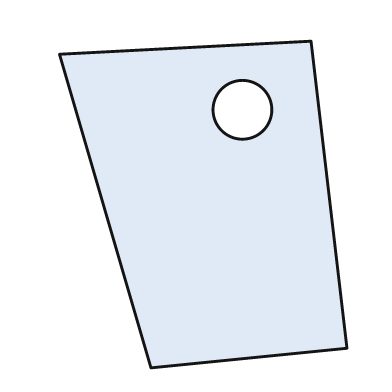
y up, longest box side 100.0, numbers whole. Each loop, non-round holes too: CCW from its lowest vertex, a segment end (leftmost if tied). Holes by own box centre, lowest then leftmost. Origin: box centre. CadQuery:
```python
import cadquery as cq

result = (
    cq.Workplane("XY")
    .moveTo(-16.0, -50.0)
    .lineTo(44.0, -44.0)
    .lineTo(33.0, 50.0)
    .lineTo(-44.0, 46.0)
    .close()
    .moveTo(12.0, 29.0)
    .circle(9.0)
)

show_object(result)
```